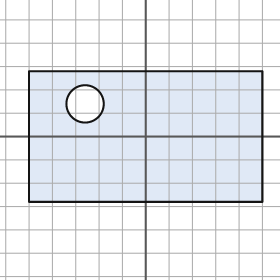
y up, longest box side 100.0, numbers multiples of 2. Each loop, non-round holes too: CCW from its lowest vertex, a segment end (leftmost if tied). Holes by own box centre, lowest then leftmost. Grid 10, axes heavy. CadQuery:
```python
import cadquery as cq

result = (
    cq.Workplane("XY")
    .moveTo(-50.0, -28.0)
    .lineTo(50.0, -28.0)
    .lineTo(50.0, 28.0)
    .lineTo(-50.0, 28.0)
    .close()
    .moveTo(-26.0, 14.0)
    .circle(8.0)
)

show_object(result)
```